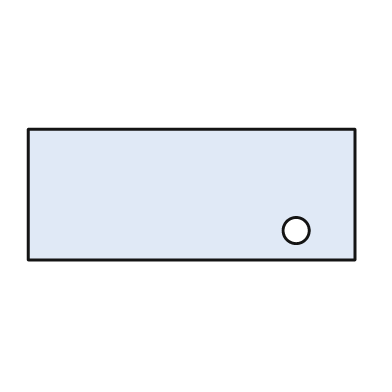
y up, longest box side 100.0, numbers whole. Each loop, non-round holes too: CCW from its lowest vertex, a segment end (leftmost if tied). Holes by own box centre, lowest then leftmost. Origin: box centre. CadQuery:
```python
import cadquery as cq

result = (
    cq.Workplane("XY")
    .moveTo(-50.0, -20.0)
    .lineTo(50.0, -20.0)
    .lineTo(50.0, 20.0)
    .lineTo(-50.0, 20.0)
    .close()
    .moveTo(32.0, -11.0)
    .circle(4.0)
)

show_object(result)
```